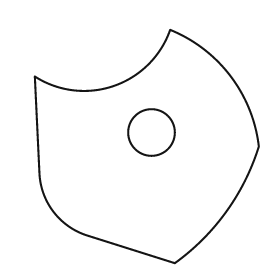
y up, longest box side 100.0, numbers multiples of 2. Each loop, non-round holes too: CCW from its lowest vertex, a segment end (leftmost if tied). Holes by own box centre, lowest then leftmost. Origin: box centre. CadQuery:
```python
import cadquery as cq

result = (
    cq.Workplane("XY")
    .moveTo(12.0, -50.0)
    .threePointArc((34.0, -28.0), (48.0, 0.0))
    .threePointArc((36.0, 30.0), (10.0, 50.0))
    .threePointArc((-14.0, 26.0), (-48.0, 30.0))
    .lineTo(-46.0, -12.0)
    .threePointArc((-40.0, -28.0), (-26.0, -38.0))
    .close()
    .moveTo(2.0, 6.0)
    .circle(10.0)
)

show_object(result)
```